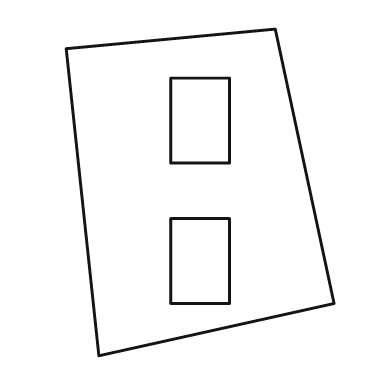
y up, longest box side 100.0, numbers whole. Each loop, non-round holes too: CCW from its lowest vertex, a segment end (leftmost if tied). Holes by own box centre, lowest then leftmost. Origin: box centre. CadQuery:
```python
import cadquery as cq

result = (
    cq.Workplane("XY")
    .moveTo(-31.0, -50.0)
    .lineTo(41.0, -34.0)
    .lineTo(23.0, 50.0)
    .lineTo(-41.0, 44.0)
    .close()
    .moveTo(-9.0, -34.0)
    .lineTo(9.0, -34.0)
    .lineTo(9.0, -8.0)
    .lineTo(-9.0, -8.0)
    .close()
    .moveTo(-9.0, 9.0)
    .lineTo(9.0, 9.0)
    .lineTo(9.0, 35.0)
    .lineTo(-9.0, 35.0)
    .close()
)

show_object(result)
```